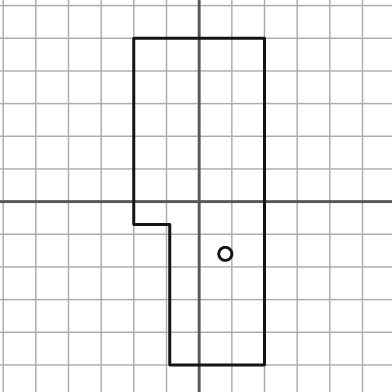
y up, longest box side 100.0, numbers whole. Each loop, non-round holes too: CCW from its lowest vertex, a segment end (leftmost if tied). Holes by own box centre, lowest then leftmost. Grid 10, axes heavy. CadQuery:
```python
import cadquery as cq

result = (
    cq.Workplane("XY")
    .moveTo(-9.0, -50.0)
    .lineTo(20.0, -50.0)
    .lineTo(20.0, 50.0)
    .lineTo(-20.0, 50.0)
    .lineTo(-20.0, -7.0)
    .lineTo(-9.0, -7.0)
    .close()
    .moveTo(8.0, -16.0)
    .circle(2.0)
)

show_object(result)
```